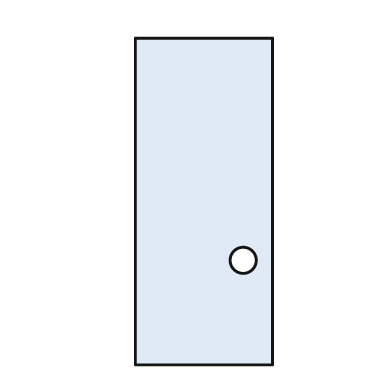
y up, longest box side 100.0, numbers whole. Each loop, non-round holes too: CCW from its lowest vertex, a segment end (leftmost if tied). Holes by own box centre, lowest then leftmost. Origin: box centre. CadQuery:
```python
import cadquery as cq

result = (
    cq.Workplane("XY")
    .moveTo(-21.0, -50.0)
    .lineTo(21.0, -50.0)
    .lineTo(21.0, 50.0)
    .lineTo(-21.0, 50.0)
    .close()
    .moveTo(12.0, -18.0)
    .circle(4.0)
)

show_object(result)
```